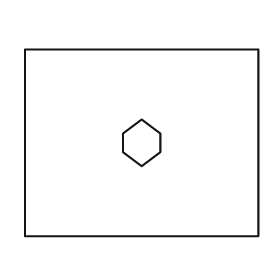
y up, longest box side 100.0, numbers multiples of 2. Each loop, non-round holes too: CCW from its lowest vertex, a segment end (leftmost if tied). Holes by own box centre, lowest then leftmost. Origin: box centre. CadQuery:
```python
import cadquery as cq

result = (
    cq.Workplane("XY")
    .moveTo(-50.0, -40.0)
    .lineTo(50.0, -40.0)
    .lineTo(50.0, 40.0)
    .lineTo(-50.0, 40.0)
    .close()
    .moveTo(0.0, -10.0)
    .lineTo(8.0, -4.0)
    .lineTo(8.0, 4.0)
    .lineTo(0.0, 10.0)
    .lineTo(-8.0, 4.0)
    .lineTo(-8.0, -4.0)
    .close()
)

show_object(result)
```